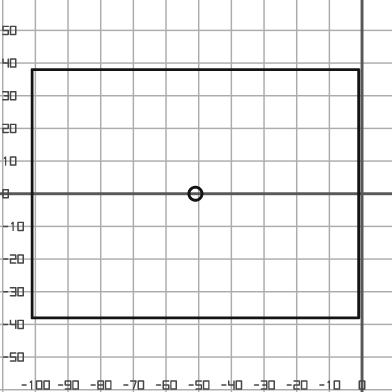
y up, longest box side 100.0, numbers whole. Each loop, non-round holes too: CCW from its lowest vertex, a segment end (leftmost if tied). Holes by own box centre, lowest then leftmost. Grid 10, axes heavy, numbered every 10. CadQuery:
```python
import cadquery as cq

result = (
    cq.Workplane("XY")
    .moveTo(-101.0, -38.0)
    .lineTo(-1.0, -38.0)
    .lineTo(-1.0, 38.0)
    .lineTo(-101.0, 38.0)
    .close()
    .moveTo(-51.0, 0.0)
    .circle(2.0)
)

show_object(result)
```